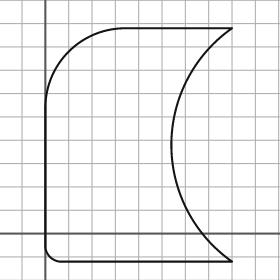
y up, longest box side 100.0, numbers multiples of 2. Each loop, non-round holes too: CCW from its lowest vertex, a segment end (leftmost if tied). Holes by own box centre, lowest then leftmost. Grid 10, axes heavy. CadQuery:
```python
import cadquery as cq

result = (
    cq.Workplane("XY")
    .moveTo(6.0, -12.0)
    .lineTo(80.0, -12.0)
    .threePointArc((54.0, 38.0), (80.0, 88.0))
    .lineTo(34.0, 88.0)
    .threePointArc((10.0, 78.0), (0.0, 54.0))
    .lineTo(0.0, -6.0)
    .threePointArc((2.0, -10.0), (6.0, -12.0))
    .close()
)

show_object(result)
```